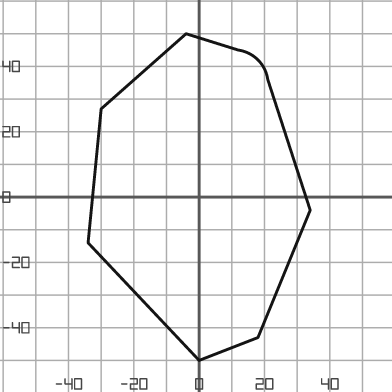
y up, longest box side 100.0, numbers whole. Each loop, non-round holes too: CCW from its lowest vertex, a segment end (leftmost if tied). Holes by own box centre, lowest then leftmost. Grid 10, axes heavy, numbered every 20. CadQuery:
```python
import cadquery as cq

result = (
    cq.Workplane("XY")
    .moveTo(0.0, -50.0)
    .lineTo(18.0, -43.0)
    .lineTo(34.0, -4.0)
    .lineTo(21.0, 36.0)
    .threePointArc((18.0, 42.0), (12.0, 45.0))
    .lineTo(-4.0, 50.0)
    .lineTo(-30.0, 27.0)
    .lineTo(-34.0, -14.0)
    .close()
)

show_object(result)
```